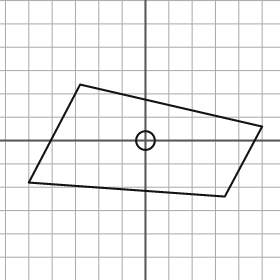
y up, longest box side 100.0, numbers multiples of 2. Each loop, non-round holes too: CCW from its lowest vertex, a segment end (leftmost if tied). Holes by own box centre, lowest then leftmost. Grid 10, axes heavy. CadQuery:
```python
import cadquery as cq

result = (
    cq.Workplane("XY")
    .moveTo(34.0, -24.0)
    .lineTo(50.0, 6.0)
    .lineTo(-28.0, 24.0)
    .lineTo(-50.0, -18.0)
    .close()
    .moveTo(0.0, 0.0)
    .circle(4.0)
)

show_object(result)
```